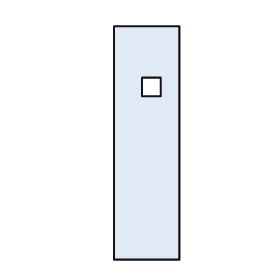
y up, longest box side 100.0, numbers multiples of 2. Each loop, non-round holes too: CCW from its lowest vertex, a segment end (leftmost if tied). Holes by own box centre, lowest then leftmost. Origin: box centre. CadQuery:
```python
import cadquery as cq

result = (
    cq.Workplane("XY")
    .moveTo(-14.0, -50.0)
    .lineTo(14.0, -50.0)
    .lineTo(14.0, 50.0)
    .lineTo(-14.0, 50.0)
    .close()
    .moveTo(-2.0, 20.0)
    .lineTo(6.0, 20.0)
    .lineTo(6.0, 28.0)
    .lineTo(-2.0, 28.0)
    .close()
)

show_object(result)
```